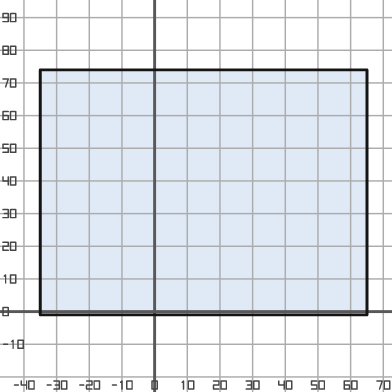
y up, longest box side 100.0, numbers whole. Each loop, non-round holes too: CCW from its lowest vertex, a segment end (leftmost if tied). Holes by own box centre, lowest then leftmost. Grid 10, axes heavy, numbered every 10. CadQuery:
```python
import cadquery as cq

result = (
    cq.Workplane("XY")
    .moveTo(-35.0, -1.0)
    .lineTo(65.0, -1.0)
    .lineTo(65.0, 74.0)
    .lineTo(-35.0, 74.0)
    .close()
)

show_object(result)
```